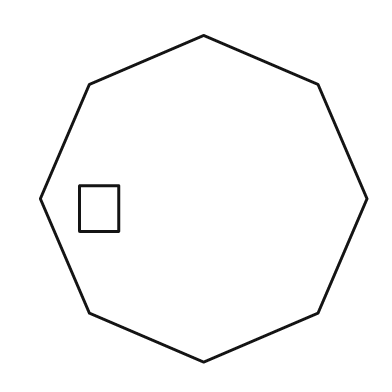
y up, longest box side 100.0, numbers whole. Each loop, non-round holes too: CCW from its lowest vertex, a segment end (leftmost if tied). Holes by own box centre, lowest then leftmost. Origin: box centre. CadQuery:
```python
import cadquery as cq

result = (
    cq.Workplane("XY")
    .moveTo(0.0, -50.0)
    .lineTo(35.0, -35.0)
    .lineTo(50.0, 0.0)
    .lineTo(35.0, 35.0)
    .lineTo(0.0, 50.0)
    .lineTo(-35.0, 35.0)
    .lineTo(-50.0, 0.0)
    .lineTo(-35.0, -35.0)
    .close()
    .moveTo(-38.0, -10.0)
    .lineTo(-26.0, -10.0)
    .lineTo(-26.0, 4.0)
    .lineTo(-38.0, 4.0)
    .close()
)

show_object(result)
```